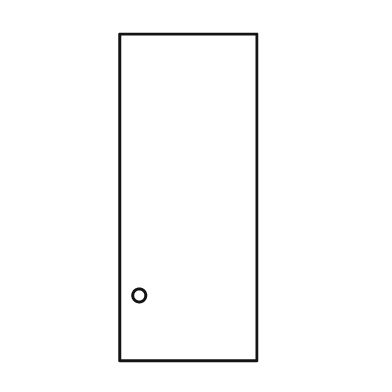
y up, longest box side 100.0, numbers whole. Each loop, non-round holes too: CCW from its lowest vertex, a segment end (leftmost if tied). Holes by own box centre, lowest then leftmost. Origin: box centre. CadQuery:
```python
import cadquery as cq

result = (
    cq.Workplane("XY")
    .moveTo(-21.0, -50.0)
    .lineTo(21.0, -50.0)
    .lineTo(21.0, 50.0)
    .lineTo(-21.0, 50.0)
    .close()
    .moveTo(-15.0, -30.0)
    .circle(2.0)
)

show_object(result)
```